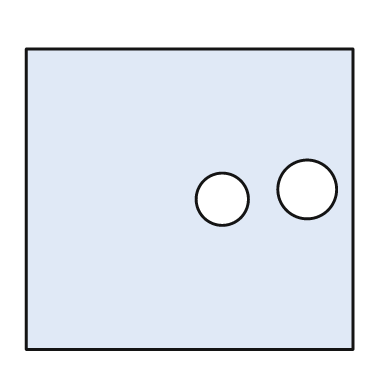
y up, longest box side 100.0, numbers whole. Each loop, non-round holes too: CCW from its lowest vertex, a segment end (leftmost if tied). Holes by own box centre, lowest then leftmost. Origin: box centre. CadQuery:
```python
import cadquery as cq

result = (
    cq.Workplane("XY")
    .moveTo(-50.0, -46.0)
    .lineTo(50.0, -46.0)
    .lineTo(50.0, 46.0)
    .lineTo(-50.0, 46.0)
    .close()
    .moveTo(10.0, 0.0)
    .circle(8.0)
    .moveTo(36.0, 3.0)
    .circle(9.0)
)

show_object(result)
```